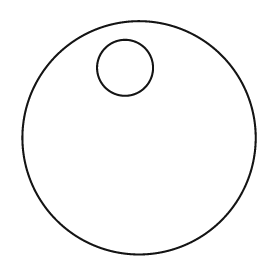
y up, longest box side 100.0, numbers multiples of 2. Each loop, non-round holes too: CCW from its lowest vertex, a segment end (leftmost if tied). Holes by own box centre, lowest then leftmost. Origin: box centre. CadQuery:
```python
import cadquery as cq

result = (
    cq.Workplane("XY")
    .moveTo(0.0, 0.0)
    .circle(50.0)
    .moveTo(-6.0, 30.0)
    .circle(12.0)
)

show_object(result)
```